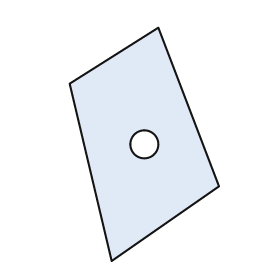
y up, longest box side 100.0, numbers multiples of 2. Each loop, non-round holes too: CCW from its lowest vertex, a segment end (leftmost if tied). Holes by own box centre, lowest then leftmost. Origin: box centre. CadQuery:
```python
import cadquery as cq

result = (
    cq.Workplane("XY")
    .moveTo(-14.0, -50.0)
    .lineTo(32.0, -18.0)
    .lineTo(6.0, 50.0)
    .lineTo(-32.0, 26.0)
    .close()
    .moveTo(0.0, 0.0)
    .circle(6.0)
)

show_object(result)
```